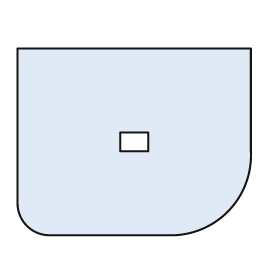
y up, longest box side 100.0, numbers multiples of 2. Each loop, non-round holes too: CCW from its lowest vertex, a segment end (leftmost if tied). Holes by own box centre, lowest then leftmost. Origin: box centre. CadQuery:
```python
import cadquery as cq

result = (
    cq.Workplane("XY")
    .moveTo(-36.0, -40.0)
    .lineTo(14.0, -40.0)
    .threePointArc((40.0, -30.0), (50.0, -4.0))
    .lineTo(50.0, 40.0)
    .lineTo(-50.0, 40.0)
    .lineTo(-50.0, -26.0)
    .threePointArc((-46.0, -36.0), (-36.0, -40.0))
    .close()
    .moveTo(-6.0, -4.0)
    .lineTo(6.0, -4.0)
    .lineTo(6.0, 4.0)
    .lineTo(-6.0, 4.0)
    .close()
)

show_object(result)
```